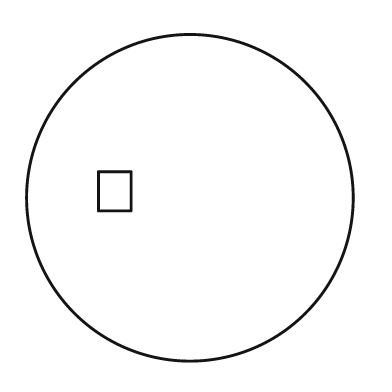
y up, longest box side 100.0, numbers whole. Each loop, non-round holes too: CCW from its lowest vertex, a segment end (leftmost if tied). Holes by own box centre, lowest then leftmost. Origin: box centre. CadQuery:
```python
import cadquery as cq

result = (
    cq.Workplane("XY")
    .moveTo(0.0, 0.0)
    .circle(50.0)
    .moveTo(-28.0, -4.0)
    .lineTo(-18.0, -4.0)
    .lineTo(-18.0, 8.0)
    .lineTo(-28.0, 8.0)
    .close()
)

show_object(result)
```